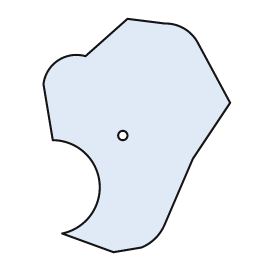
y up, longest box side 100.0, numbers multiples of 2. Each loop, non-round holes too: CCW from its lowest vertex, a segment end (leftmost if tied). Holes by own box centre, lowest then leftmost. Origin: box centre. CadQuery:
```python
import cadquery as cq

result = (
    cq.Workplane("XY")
    .moveTo(-10.0, -50.0)
    .lineTo(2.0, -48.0)
    .threePointArc((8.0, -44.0), (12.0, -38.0))
    .lineTo(24.0, -10.0)
    .lineTo(40.0, 14.0)
    .lineTo(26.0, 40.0)
    .threePointArc((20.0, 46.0), (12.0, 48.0))
    .lineTo(-4.0, 50.0)
    .lineTo(-22.0, 34.0)
    .threePointArc((-34.0, 32.0), (-40.0, 22.0))
    .lineTo(-36.0, -2.0)
    .threePointArc((-16.0, -20.0), (-32.0, -42.0))
    .close()
    .moveTo(-6.0, 0.0)
    .circle(2.0)
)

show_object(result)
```